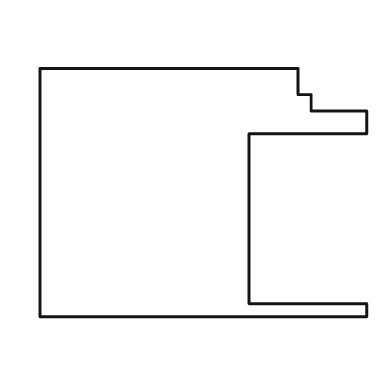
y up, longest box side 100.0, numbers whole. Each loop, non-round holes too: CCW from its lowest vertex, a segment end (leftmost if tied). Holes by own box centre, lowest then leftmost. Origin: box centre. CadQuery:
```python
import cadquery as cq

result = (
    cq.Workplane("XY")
    .moveTo(-50.0, -38.0)
    .lineTo(50.0, -38.0)
    .lineTo(50.0, -34.0)
    .lineTo(14.0, -34.0)
    .lineTo(14.0, 18.0)
    .lineTo(50.0, 18.0)
    .lineTo(50.0, 25.0)
    .lineTo(33.0, 25.0)
    .lineTo(33.0, 30.0)
    .lineTo(29.0, 30.0)
    .lineTo(29.0, 38.0)
    .lineTo(-50.0, 38.0)
    .close()
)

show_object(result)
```